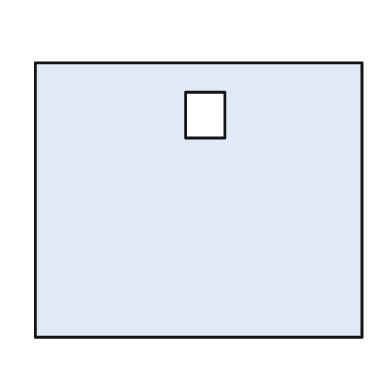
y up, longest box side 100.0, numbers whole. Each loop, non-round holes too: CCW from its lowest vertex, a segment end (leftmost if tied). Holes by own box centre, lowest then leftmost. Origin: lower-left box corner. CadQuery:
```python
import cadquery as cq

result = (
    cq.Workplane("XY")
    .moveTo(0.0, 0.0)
    .lineTo(100.0, 0.0)
    .lineTo(100.0, 84.0)
    .lineTo(0.0, 84.0)
    .close()
    .moveTo(46.0, 61.0)
    .lineTo(58.0, 61.0)
    .lineTo(58.0, 75.0)
    .lineTo(46.0, 75.0)
    .close()
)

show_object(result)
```